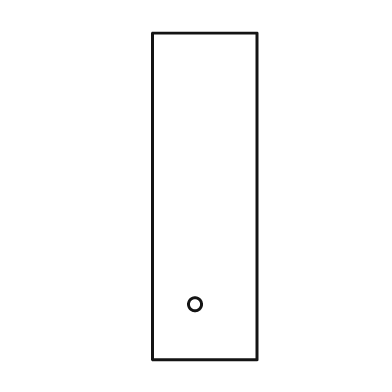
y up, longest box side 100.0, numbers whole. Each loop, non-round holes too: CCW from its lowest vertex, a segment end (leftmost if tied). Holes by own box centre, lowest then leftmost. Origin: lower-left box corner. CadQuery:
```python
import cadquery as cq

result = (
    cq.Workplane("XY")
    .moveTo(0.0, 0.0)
    .lineTo(32.0, 0.0)
    .lineTo(32.0, 100.0)
    .lineTo(0.0, 100.0)
    .close()
    .moveTo(13.0, 17.0)
    .circle(2.0)
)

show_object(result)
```